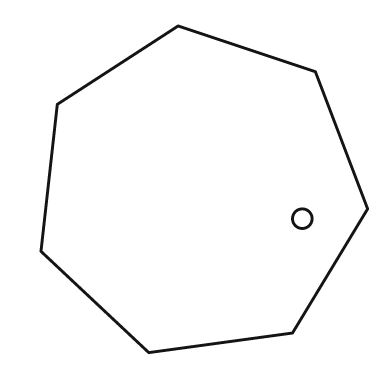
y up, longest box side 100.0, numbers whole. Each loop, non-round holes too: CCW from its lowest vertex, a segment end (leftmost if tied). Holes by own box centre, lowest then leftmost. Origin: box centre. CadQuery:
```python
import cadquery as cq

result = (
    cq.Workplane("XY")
    .moveTo(-17.0, -50.0)
    .lineTo(27.0, -44.0)
    .lineTo(50.0, -6.0)
    .lineTo(34.0, 36.0)
    .lineTo(-8.0, 50.0)
    .lineTo(-45.0, 26.0)
    .lineTo(-50.0, -19.0)
    .close()
    .moveTo(30.0, -9.0)
    .circle(3.0)
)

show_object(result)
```